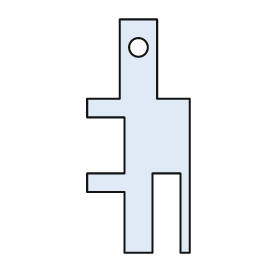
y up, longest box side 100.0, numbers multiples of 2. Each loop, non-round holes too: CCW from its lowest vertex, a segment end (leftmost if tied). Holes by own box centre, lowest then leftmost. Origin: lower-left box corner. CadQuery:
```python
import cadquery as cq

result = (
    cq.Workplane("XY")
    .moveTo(16.0, 0.0)
    .lineTo(28.0, 0.0)
    .lineTo(28.0, 34.0)
    .lineTo(40.0, 34.0)
    .lineTo(40.0, 0.0)
    .lineTo(44.0, 0.0)
    .lineTo(44.0, 66.0)
    .lineTo(30.0, 66.0)
    .lineTo(30.0, 100.0)
    .lineTo(14.0, 100.0)
    .lineTo(14.0, 66.0)
    .lineTo(0.0, 66.0)
    .lineTo(0.0, 58.0)
    .lineTo(16.0, 58.0)
    .lineTo(16.0, 34.0)
    .lineTo(0.0, 34.0)
    .lineTo(0.0, 26.0)
    .lineTo(16.0, 26.0)
    .close()
    .moveTo(22.0, 88.0)
    .circle(4.0)
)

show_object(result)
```